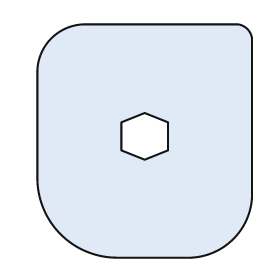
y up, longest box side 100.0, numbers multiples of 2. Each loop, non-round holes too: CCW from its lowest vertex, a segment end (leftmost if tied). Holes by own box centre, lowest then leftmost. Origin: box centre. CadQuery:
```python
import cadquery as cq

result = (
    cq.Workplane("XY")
    .moveTo(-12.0, -50.0)
    .lineTo(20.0, -50.0)
    .threePointArc((38.0, -42.0), (46.0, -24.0))
    .lineTo(46.0, 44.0)
    .threePointArc((44.0, 48.0), (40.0, 50.0))
    .lineTo(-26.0, 50.0)
    .threePointArc((-40.0, 44.0), (-46.0, 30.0))
    .lineTo(-46.0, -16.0)
    .threePointArc((-36.0, -40.0), (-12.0, -50.0))
    .close()
    .moveTo(0.0, -8.0)
    .lineTo(10.0, -4.0)
    .lineTo(10.0, 8.0)
    .lineTo(0.0, 12.0)
    .lineTo(-10.0, 8.0)
    .lineTo(-10.0, -4.0)
    .close()
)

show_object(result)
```